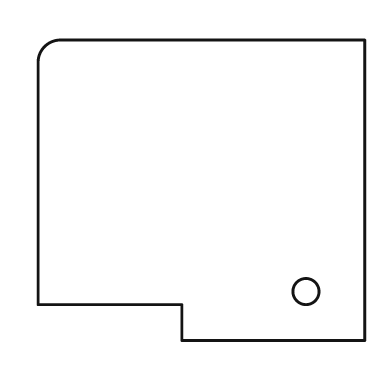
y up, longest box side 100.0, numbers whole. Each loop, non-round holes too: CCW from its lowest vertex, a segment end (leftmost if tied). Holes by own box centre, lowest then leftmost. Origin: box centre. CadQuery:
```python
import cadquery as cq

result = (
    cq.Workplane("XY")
    .moveTo(-6.0, -46.0)
    .lineTo(50.0, -46.0)
    .lineTo(50.0, 46.0)
    .lineTo(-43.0, 46.0)
    .threePointArc((-48.0, 44.0), (-50.0, 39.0))
    .lineTo(-50.0, -35.0)
    .lineTo(-6.0, -35.0)
    .close()
    .moveTo(32.0, -31.0)
    .circle(4.0)
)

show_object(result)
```